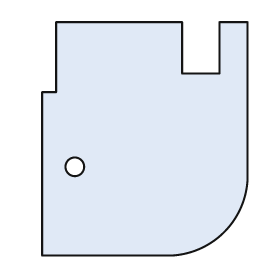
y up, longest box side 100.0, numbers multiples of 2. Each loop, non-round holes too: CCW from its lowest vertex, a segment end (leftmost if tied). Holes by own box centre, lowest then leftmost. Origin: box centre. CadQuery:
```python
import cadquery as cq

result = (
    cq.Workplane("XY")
    .moveTo(-44.0, -50.0)
    .lineTo(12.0, -50.0)
    .threePointArc((34.0, -40.0), (44.0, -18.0))
    .lineTo(44.0, 50.0)
    .lineTo(32.0, 50.0)
    .lineTo(32.0, 28.0)
    .lineTo(16.0, 28.0)
    .lineTo(16.0, 50.0)
    .lineTo(-38.0, 50.0)
    .lineTo(-38.0, 20.0)
    .lineTo(-44.0, 20.0)
    .close()
    .moveTo(-30.0, -12.0)
    .circle(4.0)
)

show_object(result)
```